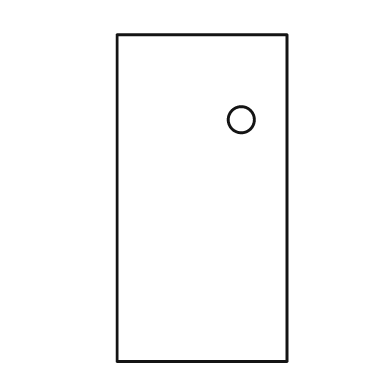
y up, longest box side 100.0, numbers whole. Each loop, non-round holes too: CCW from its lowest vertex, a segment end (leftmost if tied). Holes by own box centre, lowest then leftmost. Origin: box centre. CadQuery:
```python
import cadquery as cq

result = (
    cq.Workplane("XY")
    .moveTo(-26.0, -50.0)
    .lineTo(26.0, -50.0)
    .lineTo(26.0, 50.0)
    .lineTo(-26.0, 50.0)
    .close()
    .moveTo(12.0, 24.0)
    .circle(4.0)
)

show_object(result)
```